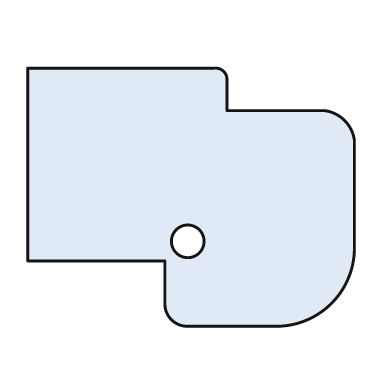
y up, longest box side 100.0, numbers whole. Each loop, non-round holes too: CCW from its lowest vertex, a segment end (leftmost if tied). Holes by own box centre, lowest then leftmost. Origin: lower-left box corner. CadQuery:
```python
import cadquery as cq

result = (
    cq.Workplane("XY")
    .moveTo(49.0, 0.0)
    .lineTo(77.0, 0.0)
    .threePointArc((93.0, 7.0), (100.0, 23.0))
    .lineTo(100.0, 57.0)
    .threePointArc((97.0, 63.0), (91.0, 66.0))
    .lineTo(61.0, 66.0)
    .lineTo(61.0, 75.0)
    .threePointArc((60.0, 78.0), (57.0, 79.0))
    .lineTo(0.0, 79.0)
    .lineTo(0.0, 20.0)
    .lineTo(42.0, 20.0)
    .lineTo(42.0, 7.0)
    .threePointArc((44.0, 2.0), (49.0, 0.0))
    .close()
    .moveTo(49.0, 26.0)
    .circle(5.0)
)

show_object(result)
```